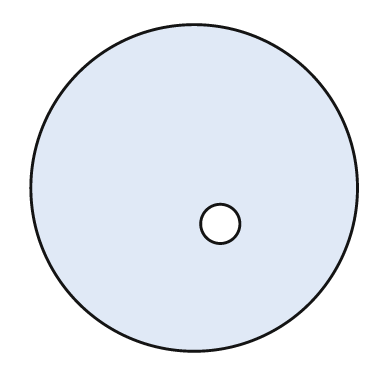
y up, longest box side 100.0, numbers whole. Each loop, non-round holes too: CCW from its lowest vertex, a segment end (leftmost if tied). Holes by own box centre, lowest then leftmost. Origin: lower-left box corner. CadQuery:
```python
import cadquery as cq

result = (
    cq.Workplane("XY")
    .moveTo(50.0, 50.0)
    .circle(50.0)
    .moveTo(58.0, 39.0)
    .circle(6.0)
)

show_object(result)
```